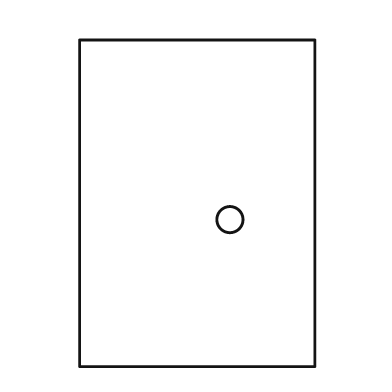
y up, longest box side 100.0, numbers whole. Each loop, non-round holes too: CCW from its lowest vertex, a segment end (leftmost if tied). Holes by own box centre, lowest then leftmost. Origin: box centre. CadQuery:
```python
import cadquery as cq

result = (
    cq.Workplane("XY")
    .moveTo(-36.0, -50.0)
    .lineTo(36.0, -50.0)
    .lineTo(36.0, 50.0)
    .lineTo(-36.0, 50.0)
    .close()
    .moveTo(10.0, -5.0)
    .circle(4.0)
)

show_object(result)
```